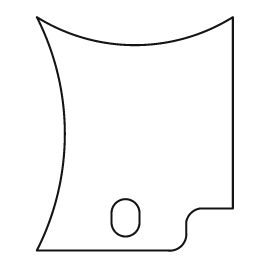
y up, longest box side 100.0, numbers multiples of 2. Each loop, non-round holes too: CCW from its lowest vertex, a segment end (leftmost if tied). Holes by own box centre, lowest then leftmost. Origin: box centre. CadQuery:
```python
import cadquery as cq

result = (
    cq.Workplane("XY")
    .moveTo(-42.0, -50.0)
    .lineTo(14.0, -50.0)
    .threePointArc((20.0, -48.0), (22.0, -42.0))
    .lineTo(22.0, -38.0)
    .threePointArc((24.0, -34.0), (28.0, -32.0))
    .lineTo(42.0, -32.0)
    .lineTo(42.0, 50.0)
    .threePointArc((0.0, 38.0), (-42.0, 50.0))
    .threePointArc((-30.0, 0.0), (-42.0, -50.0))
    .close()
    .moveTo(-10.0, -38.0)
    .threePointArc((-4.0, -44.0), (2.0, -38.0))
    .lineTo(2.0, -34.0)
    .threePointArc((-4.0, -28.0), (-10.0, -34.0))
    .close()
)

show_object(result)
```